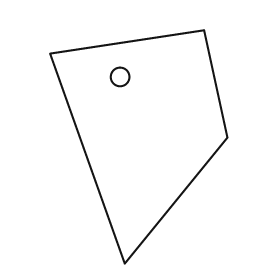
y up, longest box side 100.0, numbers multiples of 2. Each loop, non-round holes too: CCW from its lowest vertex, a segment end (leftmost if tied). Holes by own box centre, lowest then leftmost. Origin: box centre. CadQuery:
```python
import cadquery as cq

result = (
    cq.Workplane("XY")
    .moveTo(-6.0, -50.0)
    .lineTo(38.0, 4.0)
    .lineTo(28.0, 50.0)
    .lineTo(-38.0, 40.0)
    .close()
    .moveTo(-8.0, 30.0)
    .circle(4.0)
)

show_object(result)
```